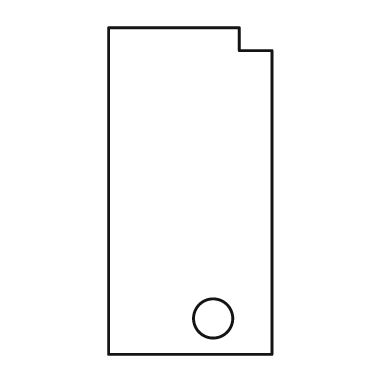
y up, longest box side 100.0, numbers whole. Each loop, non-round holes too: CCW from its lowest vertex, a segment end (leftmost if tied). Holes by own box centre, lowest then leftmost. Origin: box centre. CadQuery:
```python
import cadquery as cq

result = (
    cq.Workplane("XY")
    .moveTo(-25.0, -50.0)
    .lineTo(25.0, -50.0)
    .lineTo(25.0, 43.0)
    .lineTo(15.0, 43.0)
    .lineTo(15.0, 50.0)
    .lineTo(-25.0, 50.0)
    .close()
    .moveTo(7.0, -39.0)
    .circle(6.0)
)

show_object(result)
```